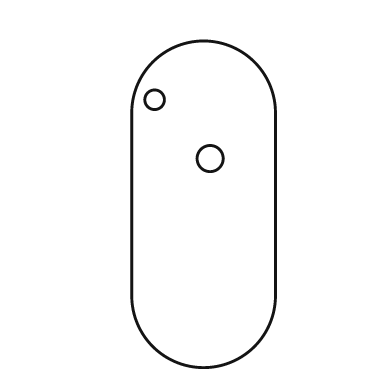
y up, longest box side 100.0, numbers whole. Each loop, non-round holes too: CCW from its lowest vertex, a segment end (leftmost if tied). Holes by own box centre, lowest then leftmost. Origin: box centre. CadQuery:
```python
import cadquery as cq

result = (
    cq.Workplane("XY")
    .moveTo(-22.0, -28.0)
    .threePointArc((0.0, -50.0), (22.0, -28.0))
    .lineTo(22.0, 28.0)
    .threePointArc((0.0, 50.0), (-22.0, 28.0))
    .close()
    .moveTo(2.0, 14.0)
    .circle(4.0)
    .moveTo(-15.0, 32.0)
    .circle(3.0)
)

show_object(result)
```